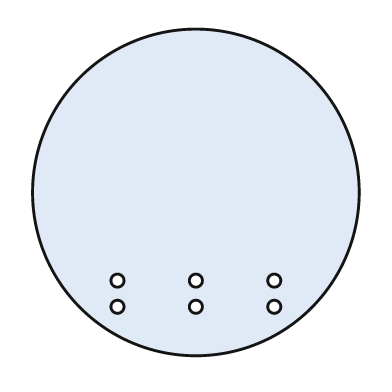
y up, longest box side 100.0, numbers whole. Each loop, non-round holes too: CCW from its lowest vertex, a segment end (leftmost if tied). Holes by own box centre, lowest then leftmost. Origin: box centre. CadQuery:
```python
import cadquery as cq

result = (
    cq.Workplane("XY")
    .moveTo(0.0, 0.0)
    .circle(50.0)
    .moveTo(-24.0, -35.0)
    .circle(2.0)
    .moveTo(0.0, -35.0)
    .circle(2.0)
    .moveTo(24.0, -35.0)
    .circle(2.0)
    .moveTo(-24.0, -27.0)
    .circle(2.0)
    .moveTo(0.0, -27.0)
    .circle(2.0)
    .moveTo(24.0, -27.0)
    .circle(2.0)
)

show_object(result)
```